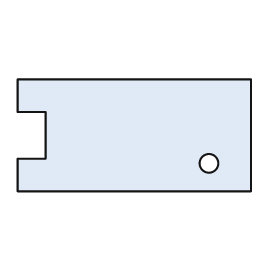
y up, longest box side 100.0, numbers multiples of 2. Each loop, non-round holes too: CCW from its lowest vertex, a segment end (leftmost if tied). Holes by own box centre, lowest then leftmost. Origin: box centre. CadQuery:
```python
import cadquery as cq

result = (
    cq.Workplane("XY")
    .moveTo(-50.0, -24.0)
    .lineTo(50.0, -24.0)
    .lineTo(50.0, 24.0)
    .lineTo(-50.0, 24.0)
    .lineTo(-50.0, 10.0)
    .lineTo(-38.0, 10.0)
    .lineTo(-38.0, -10.0)
    .lineTo(-50.0, -10.0)
    .close()
    .moveTo(32.0, -12.0)
    .circle(4.0)
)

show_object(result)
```